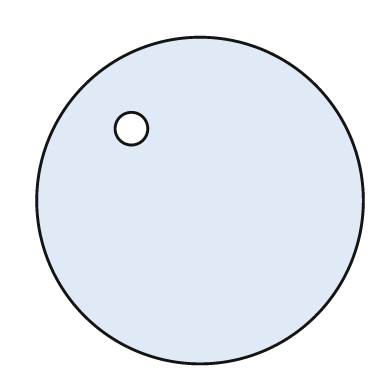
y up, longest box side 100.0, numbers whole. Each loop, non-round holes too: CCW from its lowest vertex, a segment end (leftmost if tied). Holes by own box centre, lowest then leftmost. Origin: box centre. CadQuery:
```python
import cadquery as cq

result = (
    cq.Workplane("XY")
    .moveTo(0.0, 0.0)
    .circle(50.0)
    .moveTo(-21.0, 22.0)
    .circle(5.0)
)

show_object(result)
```